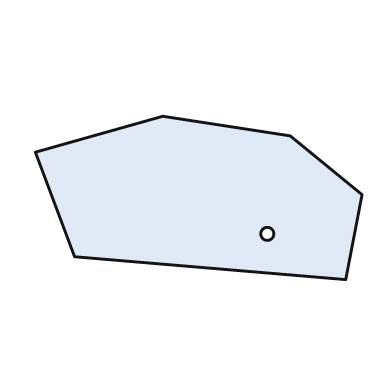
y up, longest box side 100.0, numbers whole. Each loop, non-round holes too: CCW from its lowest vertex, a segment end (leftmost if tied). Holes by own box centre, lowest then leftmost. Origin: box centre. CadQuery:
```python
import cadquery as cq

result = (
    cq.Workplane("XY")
    .moveTo(45.0, -25.0)
    .lineTo(50.0, 1.0)
    .lineTo(28.0, 19.0)
    .lineTo(-11.0, 25.0)
    .lineTo(-50.0, 14.0)
    .lineTo(-38.0, -18.0)
    .close()
    .moveTo(21.0, -11.0)
    .circle(2.0)
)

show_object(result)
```